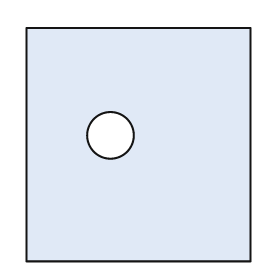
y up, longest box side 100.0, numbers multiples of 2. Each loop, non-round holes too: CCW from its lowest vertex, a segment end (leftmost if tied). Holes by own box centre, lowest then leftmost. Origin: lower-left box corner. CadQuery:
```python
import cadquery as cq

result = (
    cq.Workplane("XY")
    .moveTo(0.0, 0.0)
    .lineTo(96.0, 0.0)
    .lineTo(96.0, 100.0)
    .lineTo(0.0, 100.0)
    .close()
    .moveTo(36.0, 54.0)
    .circle(10.0)
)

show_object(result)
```